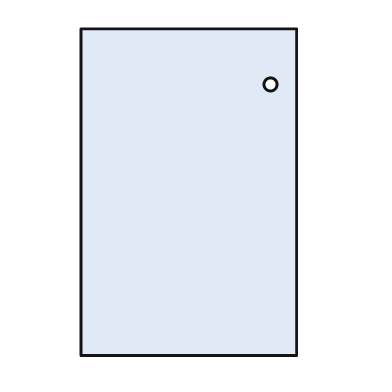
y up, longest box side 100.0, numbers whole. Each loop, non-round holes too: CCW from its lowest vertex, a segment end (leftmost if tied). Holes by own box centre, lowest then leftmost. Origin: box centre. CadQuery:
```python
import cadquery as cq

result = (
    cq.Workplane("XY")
    .moveTo(-33.0, -50.0)
    .lineTo(33.0, -50.0)
    .lineTo(33.0, 50.0)
    .lineTo(-33.0, 50.0)
    .close()
    .moveTo(25.0, 33.0)
    .circle(2.0)
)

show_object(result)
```